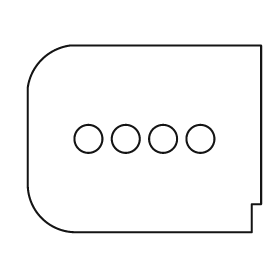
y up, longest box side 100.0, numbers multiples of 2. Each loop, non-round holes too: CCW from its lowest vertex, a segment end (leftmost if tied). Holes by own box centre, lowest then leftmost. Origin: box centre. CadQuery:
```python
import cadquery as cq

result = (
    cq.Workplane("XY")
    .moveTo(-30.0, -40.0)
    .lineTo(46.0, -40.0)
    .lineTo(46.0, -28.0)
    .lineTo(50.0, -28.0)
    .lineTo(50.0, 40.0)
    .lineTo(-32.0, 40.0)
    .threePointArc((-44.0, 34.0), (-50.0, 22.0))
    .lineTo(-50.0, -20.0)
    .threePointArc((-44.0, -34.0), (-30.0, -40.0))
    .close()
    .moveTo(-24.0, 0.0)
    .circle(6.0)
    .moveTo(-8.0, 0.0)
    .circle(6.0)
    .moveTo(8.0, 0.0)
    .circle(6.0)
    .moveTo(24.0, 0.0)
    .circle(6.0)
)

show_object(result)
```